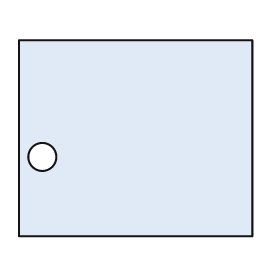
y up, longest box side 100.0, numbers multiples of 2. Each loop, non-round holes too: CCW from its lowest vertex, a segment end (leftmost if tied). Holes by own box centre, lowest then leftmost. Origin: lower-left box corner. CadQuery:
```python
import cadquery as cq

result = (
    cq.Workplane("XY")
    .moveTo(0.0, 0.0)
    .lineTo(100.0, 0.0)
    .lineTo(100.0, 84.0)
    .lineTo(0.0, 84.0)
    .close()
    .moveTo(10.0, 34.0)
    .circle(6.0)
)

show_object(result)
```